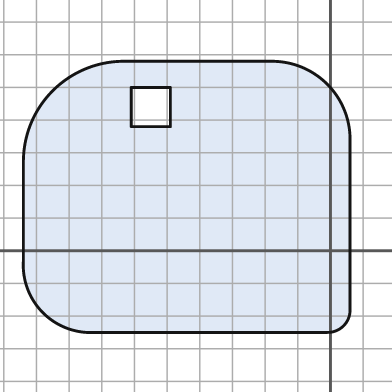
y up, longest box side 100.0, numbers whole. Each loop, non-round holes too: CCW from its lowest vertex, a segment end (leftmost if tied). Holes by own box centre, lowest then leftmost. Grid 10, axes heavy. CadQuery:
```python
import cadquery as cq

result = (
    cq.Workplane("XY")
    .moveTo(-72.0, -25.0)
    .lineTo(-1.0, -25.0)
    .threePointArc((4.0, -23.0), (6.0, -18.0))
    .lineTo(6.0, 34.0)
    .threePointArc((-1.0, 51.0), (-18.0, 58.0))
    .lineTo(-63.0, 58.0)
    .threePointArc((-85.0, 49.0), (-94.0, 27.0))
    .lineTo(-94.0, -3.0)
    .threePointArc((-88.0, -19.0), (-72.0, -25.0))
    .close()
    .moveTo(-61.0, 38.0)
    .lineTo(-49.0, 38.0)
    .lineTo(-49.0, 50.0)
    .lineTo(-61.0, 50.0)
    .close()
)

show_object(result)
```